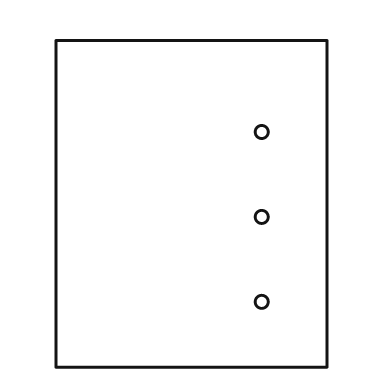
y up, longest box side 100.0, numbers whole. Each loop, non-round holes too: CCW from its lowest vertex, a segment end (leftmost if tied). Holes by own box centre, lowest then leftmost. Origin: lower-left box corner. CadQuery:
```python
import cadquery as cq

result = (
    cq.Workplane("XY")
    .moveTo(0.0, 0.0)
    .lineTo(83.0, 0.0)
    .lineTo(83.0, 100.0)
    .lineTo(0.0, 100.0)
    .close()
    .moveTo(63.0, 20.0)
    .circle(2.0)
    .moveTo(63.0, 46.0)
    .circle(2.0)
    .moveTo(63.0, 72.0)
    .circle(2.0)
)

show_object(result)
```